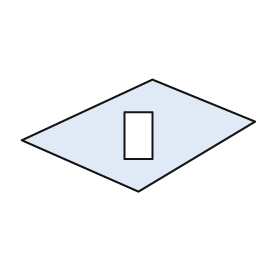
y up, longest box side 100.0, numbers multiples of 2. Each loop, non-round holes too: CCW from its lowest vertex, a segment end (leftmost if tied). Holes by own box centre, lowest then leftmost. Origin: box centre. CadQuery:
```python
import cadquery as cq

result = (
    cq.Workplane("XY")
    .moveTo(0.0, -24.0)
    .lineTo(50.0, 6.0)
    .lineTo(6.0, 24.0)
    .lineTo(-50.0, -2.0)
    .close()
    .moveTo(-6.0, -10.0)
    .lineTo(6.0, -10.0)
    .lineTo(6.0, 10.0)
    .lineTo(-6.0, 10.0)
    .close()
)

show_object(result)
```